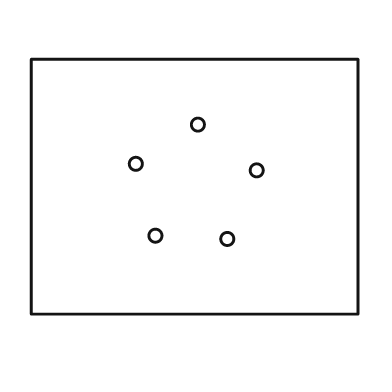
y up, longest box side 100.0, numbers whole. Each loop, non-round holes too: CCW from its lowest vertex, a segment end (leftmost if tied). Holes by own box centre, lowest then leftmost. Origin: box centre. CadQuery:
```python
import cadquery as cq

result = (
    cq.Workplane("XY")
    .moveTo(-50.0, -39.0)
    .lineTo(50.0, -39.0)
    .lineTo(50.0, 39.0)
    .lineTo(-50.0, 39.0)
    .close()
    .moveTo(10.0, -16.0)
    .circle(2.0)
    .moveTo(-12.0, -15.0)
    .circle(2.0)
    .moveTo(19.0, 5.0)
    .circle(2.0)
    .moveTo(-18.0, 7.0)
    .circle(2.0)
    .moveTo(1.0, 19.0)
    .circle(2.0)
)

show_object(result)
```